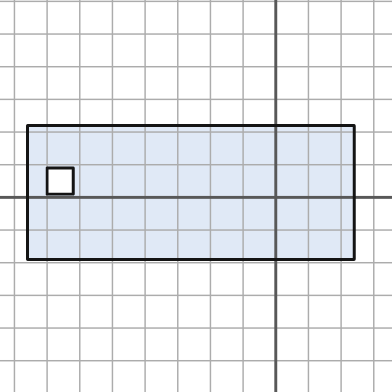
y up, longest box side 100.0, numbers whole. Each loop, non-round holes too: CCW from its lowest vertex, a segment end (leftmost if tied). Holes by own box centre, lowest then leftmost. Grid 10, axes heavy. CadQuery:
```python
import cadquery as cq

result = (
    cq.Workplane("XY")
    .moveTo(-76.0, -19.0)
    .lineTo(24.0, -19.0)
    .lineTo(24.0, 22.0)
    .lineTo(-76.0, 22.0)
    .close()
    .moveTo(-70.0, 1.0)
    .lineTo(-62.0, 1.0)
    .lineTo(-62.0, 9.0)
    .lineTo(-70.0, 9.0)
    .close()
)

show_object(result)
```